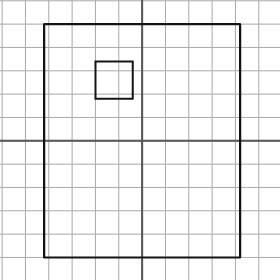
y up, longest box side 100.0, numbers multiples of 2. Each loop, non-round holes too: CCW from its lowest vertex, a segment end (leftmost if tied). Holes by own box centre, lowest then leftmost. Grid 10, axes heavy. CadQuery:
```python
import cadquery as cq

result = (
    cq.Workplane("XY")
    .moveTo(-42.0, -50.0)
    .lineTo(42.0, -50.0)
    .lineTo(42.0, 50.0)
    .lineTo(-42.0, 50.0)
    .close()
    .moveTo(-20.0, 18.0)
    .lineTo(-4.0, 18.0)
    .lineTo(-4.0, 34.0)
    .lineTo(-20.0, 34.0)
    .close()
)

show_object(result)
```